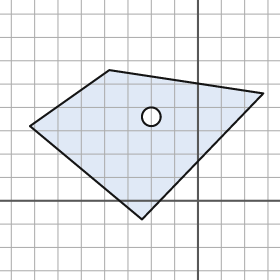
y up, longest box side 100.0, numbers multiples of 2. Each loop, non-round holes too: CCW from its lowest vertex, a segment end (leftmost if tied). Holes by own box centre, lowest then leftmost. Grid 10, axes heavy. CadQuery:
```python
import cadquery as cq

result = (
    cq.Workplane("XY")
    .moveTo(-24.0, -8.0)
    .lineTo(28.0, 46.0)
    .lineTo(-38.0, 56.0)
    .lineTo(-72.0, 32.0)
    .close()
    .moveTo(-20.0, 36.0)
    .circle(4.0)
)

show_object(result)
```